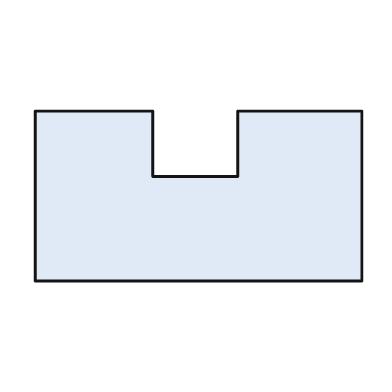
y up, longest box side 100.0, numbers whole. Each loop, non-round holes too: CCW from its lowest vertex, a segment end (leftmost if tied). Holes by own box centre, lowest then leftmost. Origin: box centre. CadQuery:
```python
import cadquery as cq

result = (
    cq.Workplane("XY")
    .moveTo(-50.0, -26.0)
    .lineTo(50.0, -26.0)
    .lineTo(50.0, 26.0)
    .lineTo(12.0, 26.0)
    .lineTo(12.0, 6.0)
    .lineTo(-14.0, 6.0)
    .lineTo(-14.0, 26.0)
    .lineTo(-50.0, 26.0)
    .close()
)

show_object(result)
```